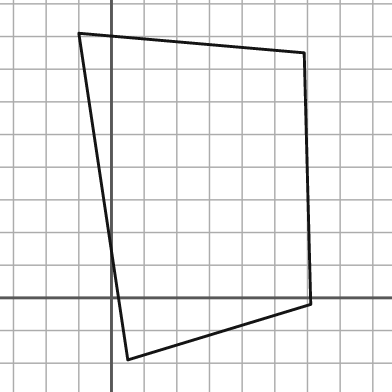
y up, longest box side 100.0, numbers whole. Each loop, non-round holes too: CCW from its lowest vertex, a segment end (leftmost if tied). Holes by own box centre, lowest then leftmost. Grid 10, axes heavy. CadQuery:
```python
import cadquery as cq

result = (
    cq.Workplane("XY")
    .moveTo(5.0, -19.0)
    .lineTo(61.0, -2.0)
    .lineTo(59.0, 75.0)
    .lineTo(-10.0, 81.0)
    .close()
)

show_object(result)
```